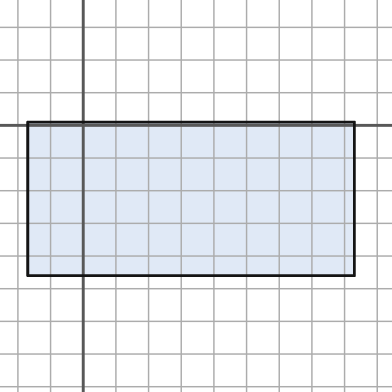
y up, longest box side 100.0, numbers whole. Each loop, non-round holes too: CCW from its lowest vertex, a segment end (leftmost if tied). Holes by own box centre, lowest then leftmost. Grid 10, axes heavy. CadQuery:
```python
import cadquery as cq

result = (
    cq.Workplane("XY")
    .moveTo(-17.0, -46.0)
    .lineTo(83.0, -46.0)
    .lineTo(83.0, 1.0)
    .lineTo(-17.0, 1.0)
    .close()
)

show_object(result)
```